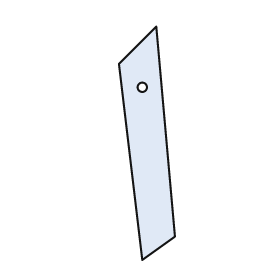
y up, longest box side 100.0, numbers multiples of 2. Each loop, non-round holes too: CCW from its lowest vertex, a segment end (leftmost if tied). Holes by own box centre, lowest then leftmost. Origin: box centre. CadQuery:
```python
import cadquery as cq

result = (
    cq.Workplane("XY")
    .moveTo(-2.0, -50.0)
    .lineTo(12.0, -40.0)
    .lineTo(4.0, 50.0)
    .lineTo(-12.0, 34.0)
    .close()
    .moveTo(-2.0, 24.0)
    .circle(2.0)
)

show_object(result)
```